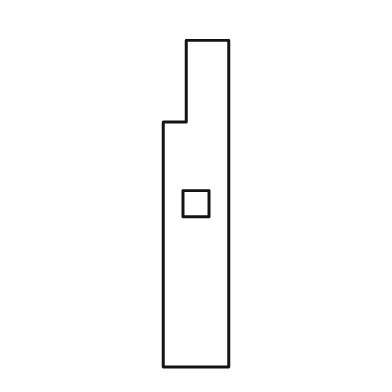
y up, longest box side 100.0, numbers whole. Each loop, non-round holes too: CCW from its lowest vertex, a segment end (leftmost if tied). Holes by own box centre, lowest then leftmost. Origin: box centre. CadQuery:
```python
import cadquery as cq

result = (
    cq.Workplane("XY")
    .moveTo(-10.0, -50.0)
    .lineTo(10.0, -50.0)
    .lineTo(10.0, 50.0)
    .lineTo(-3.0, 50.0)
    .lineTo(-3.0, 25.0)
    .lineTo(-10.0, 25.0)
    .close()
    .moveTo(-4.0, -4.0)
    .lineTo(4.0, -4.0)
    .lineTo(4.0, 4.0)
    .lineTo(-4.0, 4.0)
    .close()
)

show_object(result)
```